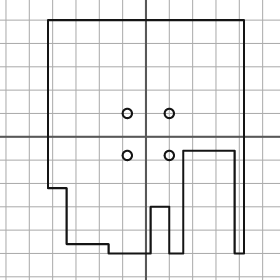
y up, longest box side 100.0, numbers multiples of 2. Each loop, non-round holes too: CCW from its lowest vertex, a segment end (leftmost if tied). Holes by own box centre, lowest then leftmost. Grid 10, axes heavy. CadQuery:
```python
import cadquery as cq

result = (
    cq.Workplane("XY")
    .moveTo(-16.0, -50.0)
    .lineTo(2.0, -50.0)
    .lineTo(2.0, -30.0)
    .lineTo(10.0, -30.0)
    .lineTo(10.0, -50.0)
    .lineTo(16.0, -50.0)
    .lineTo(16.0, -6.0)
    .lineTo(38.0, -6.0)
    .lineTo(38.0, -50.0)
    .lineTo(42.0, -50.0)
    .lineTo(42.0, 50.0)
    .lineTo(-42.0, 50.0)
    .lineTo(-42.0, -22.0)
    .lineTo(-34.0, -22.0)
    .lineTo(-34.0, -46.0)
    .lineTo(-16.0, -46.0)
    .close()
    .moveTo(-8.0, -8.0)
    .circle(2.0)
    .moveTo(10.0, -8.0)
    .circle(2.0)
    .moveTo(-8.0, 10.0)
    .circle(2.0)
    .moveTo(10.0, 10.0)
    .circle(2.0)
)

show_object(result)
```